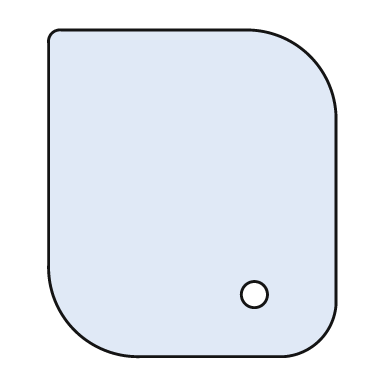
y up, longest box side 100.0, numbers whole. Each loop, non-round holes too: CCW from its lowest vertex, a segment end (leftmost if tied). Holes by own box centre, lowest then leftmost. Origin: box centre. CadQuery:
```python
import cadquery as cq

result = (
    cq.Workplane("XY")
    .moveTo(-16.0, -50.0)
    .lineTo(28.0, -50.0)
    .threePointArc((39.0, -45.0), (44.0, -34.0))
    .lineTo(44.0, 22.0)
    .threePointArc((36.0, 42.0), (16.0, 50.0))
    .lineTo(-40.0, 50.0)
    .threePointArc((-43.0, 49.0), (-44.0, 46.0))
    .lineTo(-44.0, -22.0)
    .threePointArc((-36.0, -42.0), (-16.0, -50.0))
    .close()
    .moveTo(19.0, -31.0)
    .circle(4.0)
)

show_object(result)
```